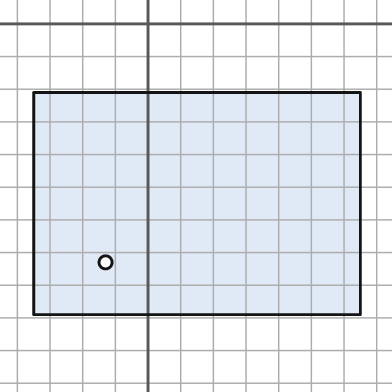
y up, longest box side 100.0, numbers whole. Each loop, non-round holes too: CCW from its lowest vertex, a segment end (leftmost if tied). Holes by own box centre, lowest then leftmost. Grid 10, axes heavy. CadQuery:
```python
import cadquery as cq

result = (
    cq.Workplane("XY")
    .moveTo(-35.0, -89.0)
    .lineTo(65.0, -89.0)
    .lineTo(65.0, -21.0)
    .lineTo(-35.0, -21.0)
    .close()
    .moveTo(-13.0, -73.0)
    .circle(2.0)
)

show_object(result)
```